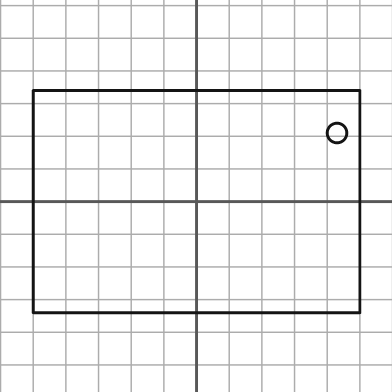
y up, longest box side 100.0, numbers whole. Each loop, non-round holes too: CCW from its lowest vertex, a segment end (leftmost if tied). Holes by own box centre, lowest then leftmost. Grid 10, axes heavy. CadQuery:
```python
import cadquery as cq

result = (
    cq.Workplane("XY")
    .moveTo(-50.0, -34.0)
    .lineTo(50.0, -34.0)
    .lineTo(50.0, 34.0)
    .lineTo(-50.0, 34.0)
    .close()
    .moveTo(43.0, 21.0)
    .circle(3.0)
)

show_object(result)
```